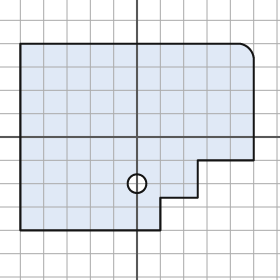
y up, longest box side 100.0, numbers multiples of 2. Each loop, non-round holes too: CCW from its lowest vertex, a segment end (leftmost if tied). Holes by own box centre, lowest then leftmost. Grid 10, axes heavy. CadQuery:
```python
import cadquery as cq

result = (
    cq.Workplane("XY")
    .moveTo(-50.0, -40.0)
    .lineTo(10.0, -40.0)
    .lineTo(10.0, -26.0)
    .lineTo(26.0, -26.0)
    .lineTo(26.0, -10.0)
    .lineTo(50.0, -10.0)
    .lineTo(50.0, 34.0)
    .threePointArc((48.0, 38.0), (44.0, 40.0))
    .lineTo(-50.0, 40.0)
    .close()
    .moveTo(0.0, -20.0)
    .circle(4.0)
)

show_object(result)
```